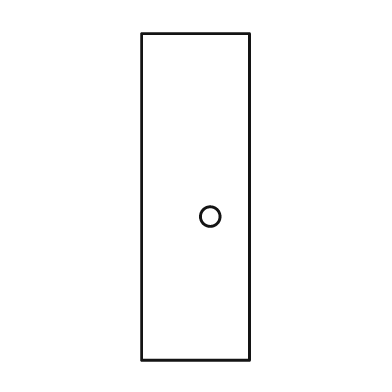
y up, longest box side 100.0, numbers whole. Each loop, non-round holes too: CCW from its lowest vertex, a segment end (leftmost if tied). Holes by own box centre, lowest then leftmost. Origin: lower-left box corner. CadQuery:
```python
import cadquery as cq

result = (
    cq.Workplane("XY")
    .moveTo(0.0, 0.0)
    .lineTo(33.0, 0.0)
    .lineTo(33.0, 100.0)
    .lineTo(0.0, 100.0)
    .close()
    .moveTo(21.0, 44.0)
    .circle(3.0)
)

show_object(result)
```